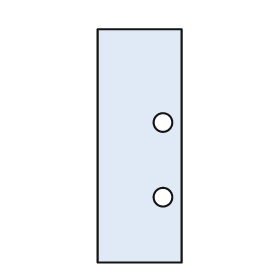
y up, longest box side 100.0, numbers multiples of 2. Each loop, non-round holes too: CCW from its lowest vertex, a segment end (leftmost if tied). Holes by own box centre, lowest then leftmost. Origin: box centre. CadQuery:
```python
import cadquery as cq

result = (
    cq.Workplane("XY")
    .moveTo(-18.0, -50.0)
    .lineTo(18.0, -50.0)
    .lineTo(18.0, 50.0)
    .lineTo(-18.0, 50.0)
    .close()
    .moveTo(10.0, -22.0)
    .circle(4.0)
    .moveTo(10.0, 10.0)
    .circle(4.0)
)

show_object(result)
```